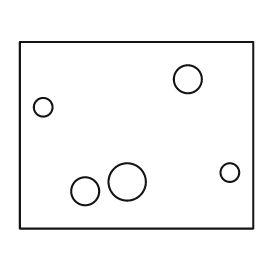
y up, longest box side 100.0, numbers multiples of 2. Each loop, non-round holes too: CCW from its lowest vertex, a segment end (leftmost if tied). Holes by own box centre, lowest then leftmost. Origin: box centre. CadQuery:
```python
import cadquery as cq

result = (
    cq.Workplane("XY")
    .moveTo(-50.0, -40.0)
    .lineTo(50.0, -40.0)
    .lineTo(50.0, 40.0)
    .lineTo(-50.0, 40.0)
    .close()
    .moveTo(-22.0, -24.0)
    .circle(6.0)
    .moveTo(-4.0, -20.0)
    .circle(8.0)
    .moveTo(40.0, -16.0)
    .circle(4.0)
    .moveTo(-40.0, 12.0)
    .circle(4.0)
    .moveTo(22.0, 24.0)
    .circle(6.0)
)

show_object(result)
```